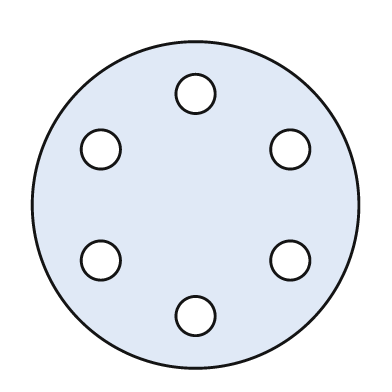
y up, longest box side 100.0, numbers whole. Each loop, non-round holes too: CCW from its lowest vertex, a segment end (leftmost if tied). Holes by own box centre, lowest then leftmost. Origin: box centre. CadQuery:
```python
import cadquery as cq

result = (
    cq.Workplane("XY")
    .moveTo(0.0, 0.0)
    .circle(50.0)
    .moveTo(0.0, -34.0)
    .circle(6.0)
    .moveTo(-29.0, -17.0)
    .circle(6.0)
    .moveTo(29.0, -17.0)
    .circle(6.0)
    .moveTo(-29.0, 17.0)
    .circle(6.0)
    .moveTo(29.0, 17.0)
    .circle(6.0)
    .moveTo(0.0, 34.0)
    .circle(6.0)
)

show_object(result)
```